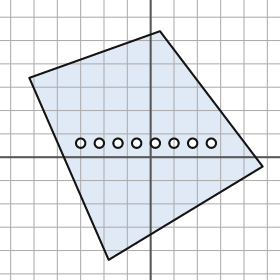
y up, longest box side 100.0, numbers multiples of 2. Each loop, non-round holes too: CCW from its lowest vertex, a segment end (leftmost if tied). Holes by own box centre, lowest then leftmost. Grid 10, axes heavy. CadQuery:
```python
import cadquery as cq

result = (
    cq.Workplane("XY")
    .moveTo(-18.0, -44.0)
    .lineTo(48.0, -4.0)
    .lineTo(4.0, 54.0)
    .lineTo(-52.0, 34.0)
    .close()
    .moveTo(-30.0, 6.0)
    .circle(2.0)
    .moveTo(-22.0, 6.0)
    .circle(2.0)
    .moveTo(-14.0, 6.0)
    .circle(2.0)
    .moveTo(-6.0, 6.0)
    .circle(2.0)
    .moveTo(2.0, 6.0)
    .circle(2.0)
    .moveTo(10.0, 6.0)
    .circle(2.0)
    .moveTo(18.0, 6.0)
    .circle(2.0)
    .moveTo(26.0, 6.0)
    .circle(2.0)
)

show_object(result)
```